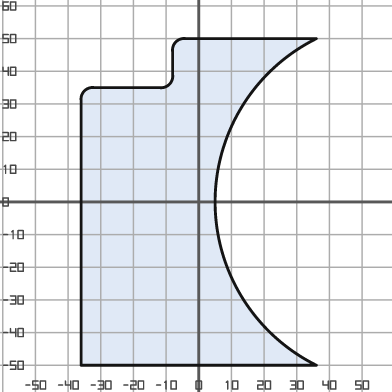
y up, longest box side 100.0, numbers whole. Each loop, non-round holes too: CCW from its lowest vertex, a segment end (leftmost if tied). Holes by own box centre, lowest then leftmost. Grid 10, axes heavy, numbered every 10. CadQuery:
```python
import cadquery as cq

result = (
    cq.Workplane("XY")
    .moveTo(-36.0, -50.0)
    .lineTo(36.0, -50.0)
    .threePointArc((5.0, 0.0), (36.0, 50.0))
    .lineTo(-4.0, 50.0)
    .threePointArc((-7.0, 49.0), (-8.0, 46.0))
    .lineTo(-8.0, 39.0)
    .threePointArc((-9.0, 36.0), (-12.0, 35.0))
    .lineTo(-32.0, 35.0)
    .threePointArc((-35.0, 34.0), (-36.0, 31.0))
    .close()
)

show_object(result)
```